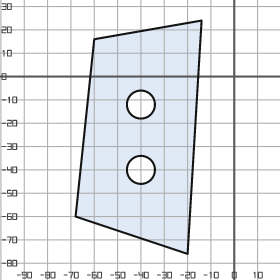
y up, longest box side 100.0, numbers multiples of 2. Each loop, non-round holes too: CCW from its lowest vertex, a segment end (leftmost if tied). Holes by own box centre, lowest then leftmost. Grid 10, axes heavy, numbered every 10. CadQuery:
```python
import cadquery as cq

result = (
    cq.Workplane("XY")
    .moveTo(-20.0, -76.0)
    .lineTo(-14.0, 24.0)
    .lineTo(-60.0, 16.0)
    .lineTo(-68.0, -60.0)
    .close()
    .moveTo(-40.0, -40.0)
    .circle(6.0)
    .moveTo(-40.0, -12.0)
    .circle(6.0)
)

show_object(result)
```